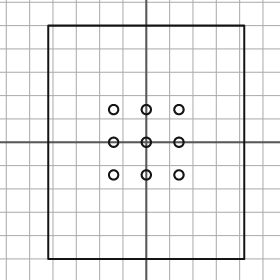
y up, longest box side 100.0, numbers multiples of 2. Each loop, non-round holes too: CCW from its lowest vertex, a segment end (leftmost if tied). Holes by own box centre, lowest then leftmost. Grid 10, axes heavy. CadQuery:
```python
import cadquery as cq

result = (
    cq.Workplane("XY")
    .moveTo(-42.0, -50.0)
    .lineTo(42.0, -50.0)
    .lineTo(42.0, 50.0)
    .lineTo(-42.0, 50.0)
    .close()
    .moveTo(-14.0, -14.0)
    .circle(2.0)
    .moveTo(0.0, -14.0)
    .circle(2.0)
    .moveTo(14.0, -14.0)
    .circle(2.0)
    .moveTo(-14.0, 0.0)
    .circle(2.0)
    .moveTo(0.0, 0.0)
    .circle(2.0)
    .moveTo(14.0, 0.0)
    .circle(2.0)
    .moveTo(-14.0, 14.0)
    .circle(2.0)
    .moveTo(0.0, 14.0)
    .circle(2.0)
    .moveTo(14.0, 14.0)
    .circle(2.0)
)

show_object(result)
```